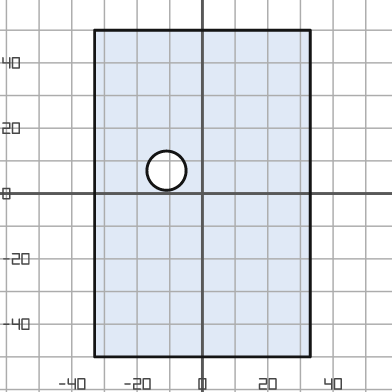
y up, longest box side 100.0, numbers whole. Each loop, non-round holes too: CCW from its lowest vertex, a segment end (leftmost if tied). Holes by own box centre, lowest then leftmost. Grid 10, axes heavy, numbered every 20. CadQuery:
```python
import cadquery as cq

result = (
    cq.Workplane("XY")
    .moveTo(-33.0, -50.0)
    .lineTo(33.0, -50.0)
    .lineTo(33.0, 50.0)
    .lineTo(-33.0, 50.0)
    .close()
    .moveTo(-11.0, 7.0)
    .circle(6.0)
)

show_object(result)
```